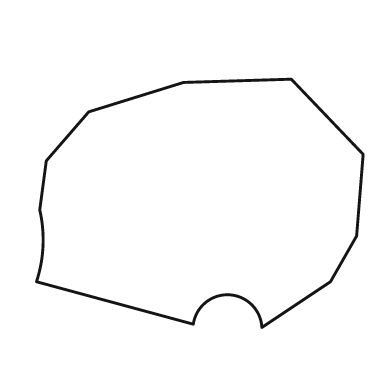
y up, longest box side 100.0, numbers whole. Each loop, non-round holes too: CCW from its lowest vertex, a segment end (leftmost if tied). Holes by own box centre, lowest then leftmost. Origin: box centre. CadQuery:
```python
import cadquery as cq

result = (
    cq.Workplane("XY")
    .moveTo(19.0, -38.0)
    .lineTo(40.0, -24.0)
    .lineTo(48.0, -10.0)
    .lineTo(50.0, 15.0)
    .lineTo(28.0, 38.0)
    .lineTo(-5.0, 37.0)
    .lineTo(-34.0, 28.0)
    .lineTo(-47.0, 13.0)
    .lineTo(-49.0, -2.0)
    .threePointArc((-48.0, -13.0), (-50.0, -24.0))
    .lineTo(-2.0, -37.0)
    .threePointArc((9.0, -28.0), (19.0, -38.0))
    .close()
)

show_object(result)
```